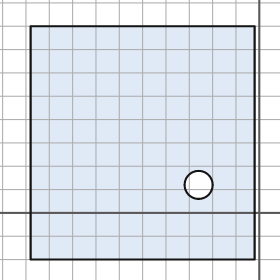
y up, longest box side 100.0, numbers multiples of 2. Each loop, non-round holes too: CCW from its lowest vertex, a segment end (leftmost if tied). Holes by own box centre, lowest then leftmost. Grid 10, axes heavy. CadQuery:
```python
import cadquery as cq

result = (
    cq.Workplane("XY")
    .moveTo(-98.0, -20.0)
    .lineTo(-2.0, -20.0)
    .lineTo(-2.0, 80.0)
    .lineTo(-98.0, 80.0)
    .close()
    .moveTo(-26.0, 12.0)
    .circle(6.0)
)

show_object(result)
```